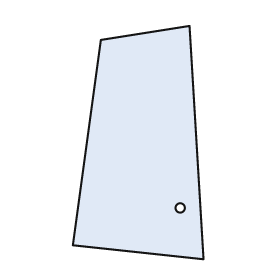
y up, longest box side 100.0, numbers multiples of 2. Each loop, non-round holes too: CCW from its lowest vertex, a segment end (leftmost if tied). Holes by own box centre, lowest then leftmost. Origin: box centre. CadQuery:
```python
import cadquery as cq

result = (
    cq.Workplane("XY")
    .moveTo(28.0, -50.0)
    .lineTo(22.0, 50.0)
    .lineTo(-16.0, 44.0)
    .lineTo(-28.0, -44.0)
    .close()
    .moveTo(18.0, -28.0)
    .circle(2.0)
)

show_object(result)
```